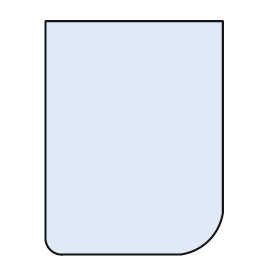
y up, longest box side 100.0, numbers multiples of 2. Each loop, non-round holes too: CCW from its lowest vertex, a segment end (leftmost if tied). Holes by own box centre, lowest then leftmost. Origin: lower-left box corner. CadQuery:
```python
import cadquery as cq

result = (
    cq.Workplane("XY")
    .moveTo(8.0, 0.0)
    .lineTo(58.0, 0.0)
    .threePointArc((70.0, 6.0), (76.0, 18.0))
    .lineTo(76.0, 100.0)
    .lineTo(0.0, 100.0)
    .lineTo(0.0, 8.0)
    .threePointArc((2.0, 2.0), (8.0, 0.0))
    .close()
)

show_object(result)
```